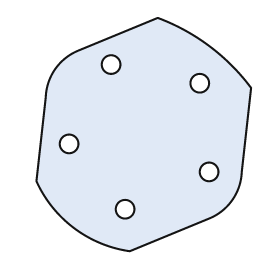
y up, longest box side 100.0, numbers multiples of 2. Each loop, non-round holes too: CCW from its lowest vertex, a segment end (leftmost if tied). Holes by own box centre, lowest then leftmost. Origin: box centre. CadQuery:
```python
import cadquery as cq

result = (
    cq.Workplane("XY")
    .moveTo(-6.0, -50.0)
    .lineTo(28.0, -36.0)
    .threePointArc((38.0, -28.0), (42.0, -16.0))
    .lineTo(46.0, 20.0)
    .threePointArc((28.0, 38.0), (6.0, 50.0))
    .lineTo(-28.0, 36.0)
    .threePointArc((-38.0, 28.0), (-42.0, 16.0))
    .lineTo(-46.0, -20.0)
    .threePointArc((-30.0, -40.0), (-6.0, -50.0))
    .close()
    .moveTo(-8.0, -32.0)
    .circle(4.0)
    .moveTo(28.0, -16.0)
    .circle(4.0)
    .moveTo(-32.0, -4.0)
    .circle(4.0)
    .moveTo(24.0, 22.0)
    .circle(4.0)
    .moveTo(-14.0, 30.0)
    .circle(4.0)
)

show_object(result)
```